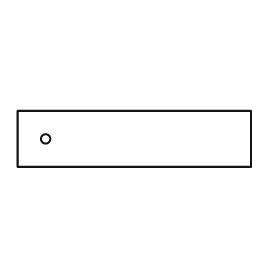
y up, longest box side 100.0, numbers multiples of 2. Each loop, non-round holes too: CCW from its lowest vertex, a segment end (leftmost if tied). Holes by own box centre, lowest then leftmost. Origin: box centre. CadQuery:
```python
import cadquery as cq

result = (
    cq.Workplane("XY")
    .moveTo(-50.0, -12.0)
    .lineTo(50.0, -12.0)
    .lineTo(50.0, 12.0)
    .lineTo(-50.0, 12.0)
    .close()
    .moveTo(-38.0, 0.0)
    .circle(2.0)
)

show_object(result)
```